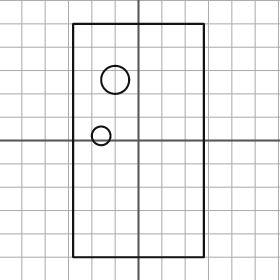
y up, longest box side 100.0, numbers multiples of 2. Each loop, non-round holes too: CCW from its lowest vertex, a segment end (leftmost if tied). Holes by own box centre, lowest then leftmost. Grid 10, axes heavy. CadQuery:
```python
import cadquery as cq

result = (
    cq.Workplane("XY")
    .moveTo(-28.0, -50.0)
    .lineTo(28.0, -50.0)
    .lineTo(28.0, 50.0)
    .lineTo(-28.0, 50.0)
    .close()
    .moveTo(-16.0, 2.0)
    .circle(4.0)
    .moveTo(-10.0, 26.0)
    .circle(6.0)
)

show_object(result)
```